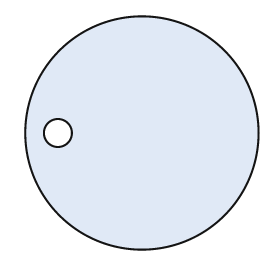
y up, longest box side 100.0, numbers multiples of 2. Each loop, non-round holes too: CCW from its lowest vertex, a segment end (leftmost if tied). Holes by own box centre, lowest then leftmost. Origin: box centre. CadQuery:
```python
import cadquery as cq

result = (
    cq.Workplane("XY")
    .moveTo(0.0, 0.0)
    .circle(50.0)
    .moveTo(-36.0, 0.0)
    .circle(6.0)
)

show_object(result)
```